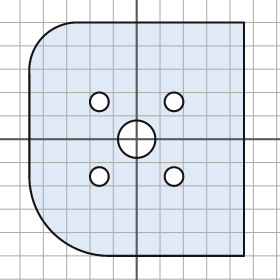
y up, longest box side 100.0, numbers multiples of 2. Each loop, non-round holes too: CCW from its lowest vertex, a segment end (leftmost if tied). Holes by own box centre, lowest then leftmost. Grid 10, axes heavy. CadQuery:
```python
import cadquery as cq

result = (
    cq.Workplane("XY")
    .moveTo(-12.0, -50.0)
    .lineTo(46.0, -50.0)
    .lineTo(46.0, 50.0)
    .lineTo(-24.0, 50.0)
    .threePointArc((-40.0, 44.0), (-46.0, 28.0))
    .lineTo(-46.0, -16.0)
    .threePointArc((-36.0, -40.0), (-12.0, -50.0))
    .close()
    .moveTo(-16.0, -16.0)
    .circle(4.0)
    .moveTo(16.0, -16.0)
    .circle(4.0)
    .moveTo(0.0, 0.0)
    .circle(8.0)
    .moveTo(-16.0, 16.0)
    .circle(4.0)
    .moveTo(16.0, 16.0)
    .circle(4.0)
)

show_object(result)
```